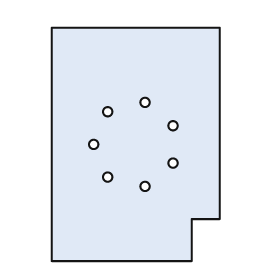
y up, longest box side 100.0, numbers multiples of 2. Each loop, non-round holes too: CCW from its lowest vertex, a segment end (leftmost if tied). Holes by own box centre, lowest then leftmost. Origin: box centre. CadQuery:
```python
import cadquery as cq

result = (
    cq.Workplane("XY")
    .moveTo(-36.0, -50.0)
    .lineTo(24.0, -50.0)
    .lineTo(24.0, -32.0)
    .lineTo(36.0, -32.0)
    .lineTo(36.0, 50.0)
    .lineTo(-36.0, 50.0)
    .close()
    .moveTo(4.0, -18.0)
    .circle(2.0)
    .moveTo(-12.0, -14.0)
    .circle(2.0)
    .moveTo(16.0, -8.0)
    .circle(2.0)
    .moveTo(-18.0, 0.0)
    .circle(2.0)
    .moveTo(16.0, 8.0)
    .circle(2.0)
    .moveTo(-12.0, 14.0)
    .circle(2.0)
    .moveTo(4.0, 18.0)
    .circle(2.0)
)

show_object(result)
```